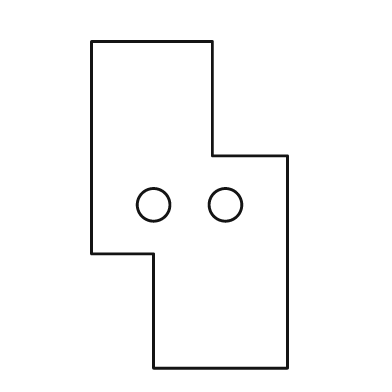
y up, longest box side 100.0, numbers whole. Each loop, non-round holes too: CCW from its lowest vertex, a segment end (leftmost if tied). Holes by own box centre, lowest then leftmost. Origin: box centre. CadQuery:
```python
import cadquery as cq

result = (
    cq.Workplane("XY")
    .moveTo(-11.0, -50.0)
    .lineTo(30.0, -50.0)
    .lineTo(30.0, 15.0)
    .lineTo(7.0, 15.0)
    .lineTo(7.0, 50.0)
    .lineTo(-30.0, 50.0)
    .lineTo(-30.0, -15.0)
    .lineTo(-11.0, -15.0)
    .close()
    .moveTo(-11.0, 0.0)
    .circle(5.0)
    .moveTo(11.0, 0.0)
    .circle(5.0)
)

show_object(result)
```